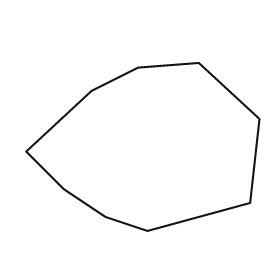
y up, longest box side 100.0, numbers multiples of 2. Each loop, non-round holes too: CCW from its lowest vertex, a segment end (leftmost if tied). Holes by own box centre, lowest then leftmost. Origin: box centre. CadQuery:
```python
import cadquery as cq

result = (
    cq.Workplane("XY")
    .moveTo(2.0, -36.0)
    .lineTo(46.0, -24.0)
    .lineTo(50.0, 12.0)
    .lineTo(24.0, 36.0)
    .lineTo(-2.0, 34.0)
    .lineTo(-22.0, 24.0)
    .lineTo(-50.0, -2.0)
    .lineTo(-34.0, -18.0)
    .lineTo(-16.0, -30.0)
    .close()
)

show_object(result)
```